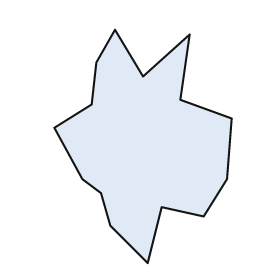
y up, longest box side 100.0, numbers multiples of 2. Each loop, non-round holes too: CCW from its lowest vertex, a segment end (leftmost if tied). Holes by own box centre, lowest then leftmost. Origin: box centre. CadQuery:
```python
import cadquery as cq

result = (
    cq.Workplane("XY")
    .moveTo(2.0, -50.0)
    .lineTo(8.0, -26.0)
    .lineTo(26.0, -30.0)
    .lineTo(36.0, -14.0)
    .lineTo(38.0, 12.0)
    .lineTo(16.0, 20.0)
    .lineTo(20.0, 48.0)
    .lineTo(0.0, 30.0)
    .lineTo(-12.0, 50.0)
    .lineTo(-20.0, 36.0)
    .lineTo(-22.0, 18.0)
    .lineTo(-38.0, 8.0)
    .lineTo(-26.0, -14.0)
    .lineTo(-18.0, -20.0)
    .lineTo(-14.0, -34.0)
    .close()
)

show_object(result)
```